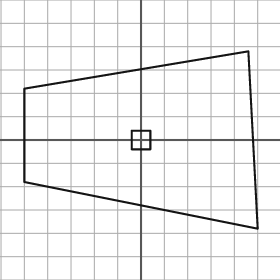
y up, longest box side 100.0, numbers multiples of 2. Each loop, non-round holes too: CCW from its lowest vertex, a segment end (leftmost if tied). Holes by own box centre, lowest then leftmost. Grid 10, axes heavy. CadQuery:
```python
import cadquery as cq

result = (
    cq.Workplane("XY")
    .moveTo(50.0, -38.0)
    .lineTo(46.0, 38.0)
    .lineTo(-50.0, 22.0)
    .lineTo(-50.0, -18.0)
    .close()
    .moveTo(-4.0, -4.0)
    .lineTo(4.0, -4.0)
    .lineTo(4.0, 4.0)
    .lineTo(-4.0, 4.0)
    .close()
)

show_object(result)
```